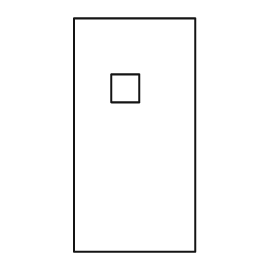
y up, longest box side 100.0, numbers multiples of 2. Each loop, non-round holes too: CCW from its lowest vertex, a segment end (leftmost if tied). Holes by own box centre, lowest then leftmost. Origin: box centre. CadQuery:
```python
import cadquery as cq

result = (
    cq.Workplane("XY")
    .moveTo(-26.0, -50.0)
    .lineTo(26.0, -50.0)
    .lineTo(26.0, 50.0)
    .lineTo(-26.0, 50.0)
    .close()
    .moveTo(-10.0, 14.0)
    .lineTo(2.0, 14.0)
    .lineTo(2.0, 26.0)
    .lineTo(-10.0, 26.0)
    .close()
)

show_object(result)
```